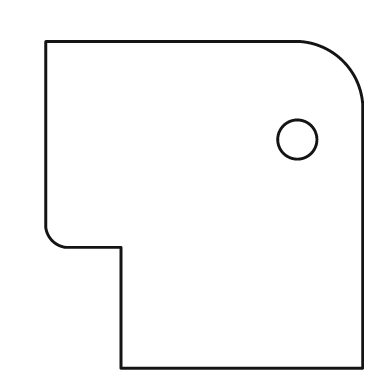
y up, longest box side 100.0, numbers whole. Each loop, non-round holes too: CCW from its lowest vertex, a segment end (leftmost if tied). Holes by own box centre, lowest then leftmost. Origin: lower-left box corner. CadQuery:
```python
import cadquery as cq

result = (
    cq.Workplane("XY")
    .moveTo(23.0, 0.0)
    .lineTo(97.0, 0.0)
    .lineTo(97.0, 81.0)
    .threePointArc((91.0, 94.0), (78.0, 100.0))
    .lineTo(0.0, 100.0)
    .lineTo(0.0, 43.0)
    .threePointArc((2.0, 39.0), (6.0, 37.0))
    .lineTo(23.0, 37.0)
    .close()
    .moveTo(77.0, 70.0)
    .circle(6.0)
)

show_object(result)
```